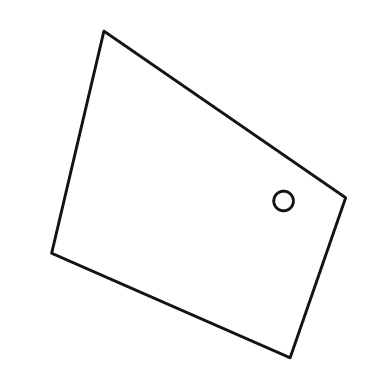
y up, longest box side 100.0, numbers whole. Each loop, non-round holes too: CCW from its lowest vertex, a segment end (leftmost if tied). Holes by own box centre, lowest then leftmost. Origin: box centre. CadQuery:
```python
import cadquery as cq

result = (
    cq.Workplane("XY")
    .moveTo(28.0, -50.0)
    .lineTo(45.0, -1.0)
    .lineTo(-29.0, 50.0)
    .lineTo(-45.0, -18.0)
    .close()
    .moveTo(26.0, -2.0)
    .circle(3.0)
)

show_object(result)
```